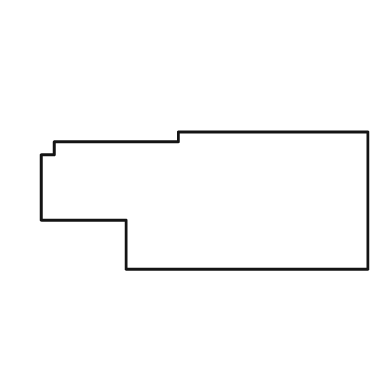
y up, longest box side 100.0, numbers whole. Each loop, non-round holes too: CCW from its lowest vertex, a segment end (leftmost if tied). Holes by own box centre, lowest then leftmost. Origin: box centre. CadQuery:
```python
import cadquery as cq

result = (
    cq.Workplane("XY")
    .moveTo(-24.0, -21.0)
    .lineTo(50.0, -21.0)
    .lineTo(50.0, 21.0)
    .lineTo(-8.0, 21.0)
    .lineTo(-8.0, 18.0)
    .lineTo(-46.0, 18.0)
    .lineTo(-46.0, 14.0)
    .lineTo(-50.0, 14.0)
    .lineTo(-50.0, -6.0)
    .lineTo(-24.0, -6.0)
    .close()
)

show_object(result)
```